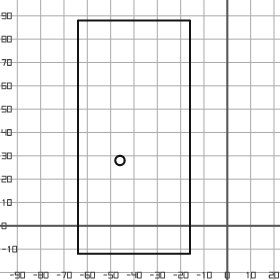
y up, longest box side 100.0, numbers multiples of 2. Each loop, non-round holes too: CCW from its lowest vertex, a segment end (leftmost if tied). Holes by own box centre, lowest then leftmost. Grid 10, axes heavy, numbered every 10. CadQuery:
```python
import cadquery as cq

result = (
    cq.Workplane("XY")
    .moveTo(-64.0, -12.0)
    .lineTo(-16.0, -12.0)
    .lineTo(-16.0, 88.0)
    .lineTo(-64.0, 88.0)
    .close()
    .moveTo(-46.0, 28.0)
    .circle(2.0)
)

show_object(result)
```